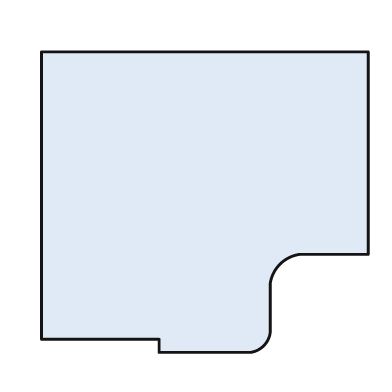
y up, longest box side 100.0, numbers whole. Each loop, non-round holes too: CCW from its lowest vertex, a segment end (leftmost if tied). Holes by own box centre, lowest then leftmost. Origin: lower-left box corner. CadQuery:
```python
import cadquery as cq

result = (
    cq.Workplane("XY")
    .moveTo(36.0, 0.0)
    .lineTo(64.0, 0.0)
    .threePointArc((68.0, 2.0), (70.0, 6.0))
    .lineTo(70.0, 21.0)
    .threePointArc((73.0, 27.0), (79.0, 30.0))
    .lineTo(100.0, 30.0)
    .lineTo(100.0, 92.0)
    .lineTo(0.0, 92.0)
    .lineTo(0.0, 4.0)
    .lineTo(36.0, 4.0)
    .close()
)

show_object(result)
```